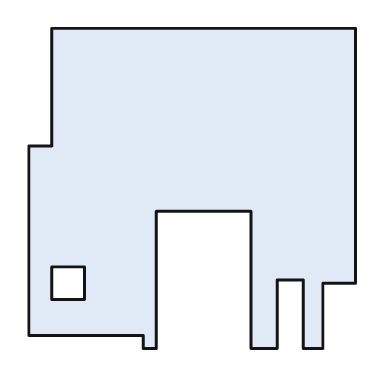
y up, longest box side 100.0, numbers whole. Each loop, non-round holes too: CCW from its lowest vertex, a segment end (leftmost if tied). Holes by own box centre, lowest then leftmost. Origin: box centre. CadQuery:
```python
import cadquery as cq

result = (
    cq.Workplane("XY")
    .moveTo(-15.0, -49.0)
    .lineTo(-11.0, -49.0)
    .lineTo(-11.0, -7.0)
    .lineTo(18.0, -7.0)
    .lineTo(18.0, -49.0)
    .lineTo(26.0, -49.0)
    .lineTo(26.0, -28.0)
    .lineTo(34.0, -28.0)
    .lineTo(34.0, -49.0)
    .lineTo(40.0, -49.0)
    .lineTo(40.0, -29.0)
    .lineTo(50.0, -29.0)
    .lineTo(50.0, 49.0)
    .lineTo(-43.0, 49.0)
    .lineTo(-43.0, 13.0)
    .lineTo(-50.0, 13.0)
    .lineTo(-50.0, -45.0)
    .lineTo(-15.0, -45.0)
    .close()
    .moveTo(-43.0, -34.0)
    .lineTo(-33.0, -34.0)
    .lineTo(-33.0, -24.0)
    .lineTo(-43.0, -24.0)
    .close()
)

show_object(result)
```